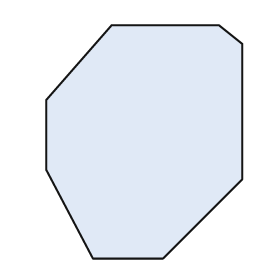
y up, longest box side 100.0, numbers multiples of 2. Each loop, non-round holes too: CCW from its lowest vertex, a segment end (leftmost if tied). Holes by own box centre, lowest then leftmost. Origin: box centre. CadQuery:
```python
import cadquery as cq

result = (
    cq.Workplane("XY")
    .moveTo(-22.0, -50.0)
    .lineTo(8.0, -50.0)
    .lineTo(42.0, -16.0)
    .lineTo(42.0, 42.0)
    .lineTo(32.0, 50.0)
    .lineTo(-14.0, 50.0)
    .lineTo(-42.0, 18.0)
    .lineTo(-42.0, -12.0)
    .close()
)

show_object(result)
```